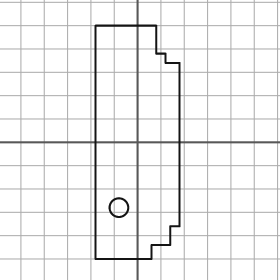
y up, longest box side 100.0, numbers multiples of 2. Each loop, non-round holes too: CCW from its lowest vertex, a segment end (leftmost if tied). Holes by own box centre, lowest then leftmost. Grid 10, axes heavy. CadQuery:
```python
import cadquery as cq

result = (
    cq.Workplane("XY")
    .moveTo(-18.0, -50.0)
    .lineTo(6.0, -50.0)
    .lineTo(6.0, -44.0)
    .lineTo(14.0, -44.0)
    .lineTo(14.0, -36.0)
    .lineTo(18.0, -36.0)
    .lineTo(18.0, 34.0)
    .lineTo(12.0, 34.0)
    .lineTo(12.0, 38.0)
    .lineTo(8.0, 38.0)
    .lineTo(8.0, 50.0)
    .lineTo(-18.0, 50.0)
    .close()
    .moveTo(-8.0, -28.0)
    .circle(4.0)
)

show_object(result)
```